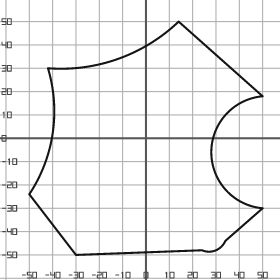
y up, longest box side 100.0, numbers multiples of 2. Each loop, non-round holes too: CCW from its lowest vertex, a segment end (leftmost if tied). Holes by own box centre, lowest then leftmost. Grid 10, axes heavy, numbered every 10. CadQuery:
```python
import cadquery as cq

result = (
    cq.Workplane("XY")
    .moveTo(-30.0, -50.0)
    .lineTo(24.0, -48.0)
    .threePointArc((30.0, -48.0), (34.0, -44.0))
    .lineTo(50.0, -30.0)
    .threePointArc((28.0, -6.0), (50.0, 18.0))
    .lineTo(14.0, 50.0)
    .threePointArc((-12.0, 34.0), (-42.0, 30.0))
    .threePointArc((-40.0, 2.0), (-50.0, -24.0))
    .close()
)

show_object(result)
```